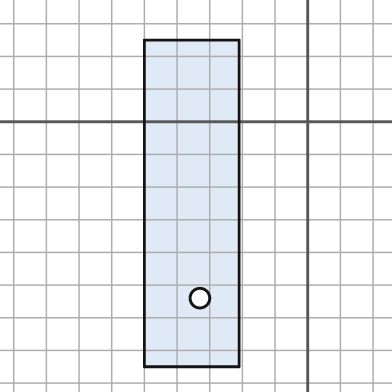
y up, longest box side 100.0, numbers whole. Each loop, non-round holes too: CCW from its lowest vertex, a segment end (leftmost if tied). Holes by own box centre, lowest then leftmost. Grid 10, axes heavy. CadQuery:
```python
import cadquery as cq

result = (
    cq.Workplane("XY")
    .moveTo(-50.0, -75.0)
    .lineTo(-21.0, -75.0)
    .lineTo(-21.0, 25.0)
    .lineTo(-50.0, 25.0)
    .close()
    .moveTo(-33.0, -54.0)
    .circle(3.0)
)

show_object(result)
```